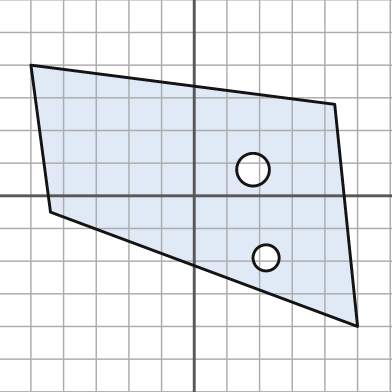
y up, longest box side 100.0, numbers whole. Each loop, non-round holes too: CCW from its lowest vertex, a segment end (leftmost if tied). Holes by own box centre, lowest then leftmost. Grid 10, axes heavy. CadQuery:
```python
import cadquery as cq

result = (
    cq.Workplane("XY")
    .moveTo(50.0, -40.0)
    .lineTo(43.0, 28.0)
    .lineTo(-50.0, 40.0)
    .lineTo(-44.0, -5.0)
    .close()
    .moveTo(22.0, -19.0)
    .circle(4.0)
    .moveTo(18.0, 8.0)
    .circle(5.0)
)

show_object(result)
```